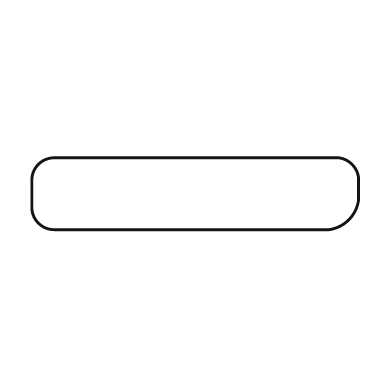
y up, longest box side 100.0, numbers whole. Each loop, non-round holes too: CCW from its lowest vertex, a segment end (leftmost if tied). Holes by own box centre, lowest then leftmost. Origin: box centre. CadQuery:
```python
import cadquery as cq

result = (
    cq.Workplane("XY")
    .moveTo(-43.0, -11.0)
    .lineTo(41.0, -11.0)
    .threePointArc((47.0, -8.0), (50.0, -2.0))
    .lineTo(50.0, 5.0)
    .threePointArc((48.0, 9.0), (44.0, 11.0))
    .lineTo(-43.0, 11.0)
    .threePointArc((-48.0, 9.0), (-50.0, 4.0))
    .lineTo(-50.0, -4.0)
    .threePointArc((-48.0, -9.0), (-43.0, -11.0))
    .close()
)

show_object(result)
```